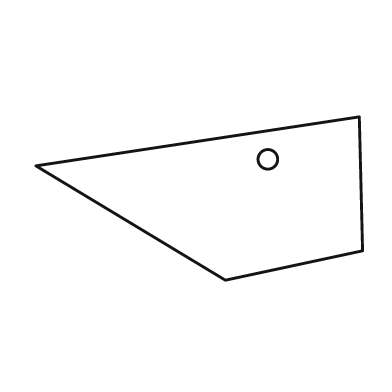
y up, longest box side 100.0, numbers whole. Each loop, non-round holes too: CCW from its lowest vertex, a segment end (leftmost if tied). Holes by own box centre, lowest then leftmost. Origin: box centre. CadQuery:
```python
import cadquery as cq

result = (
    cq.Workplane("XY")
    .moveTo(8.0, -25.0)
    .lineTo(50.0, -16.0)
    .lineTo(49.0, 25.0)
    .lineTo(-50.0, 10.0)
    .close()
    .moveTo(21.0, 12.0)
    .circle(3.0)
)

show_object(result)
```